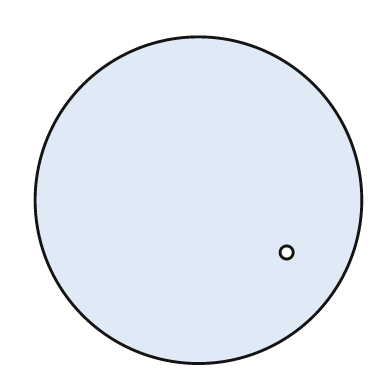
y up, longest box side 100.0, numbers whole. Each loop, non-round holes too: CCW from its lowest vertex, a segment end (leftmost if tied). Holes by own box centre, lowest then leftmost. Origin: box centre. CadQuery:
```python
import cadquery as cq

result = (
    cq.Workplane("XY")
    .moveTo(0.0, 0.0)
    .circle(50.0)
    .moveTo(27.0, -16.0)
    .circle(2.0)
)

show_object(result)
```